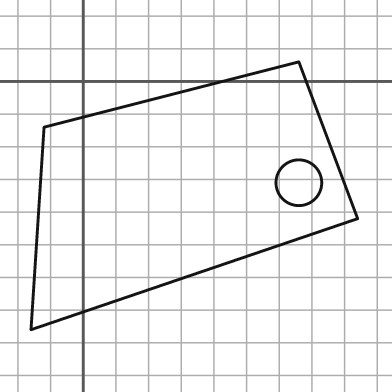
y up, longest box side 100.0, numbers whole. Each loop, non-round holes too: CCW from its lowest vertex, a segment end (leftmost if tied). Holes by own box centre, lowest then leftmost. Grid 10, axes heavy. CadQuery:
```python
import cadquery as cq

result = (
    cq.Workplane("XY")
    .moveTo(-16.0, -76.0)
    .lineTo(84.0, -42.0)
    .lineTo(66.0, 6.0)
    .lineTo(-12.0, -14.0)
    .close()
    .moveTo(66.0, -31.0)
    .circle(7.0)
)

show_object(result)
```